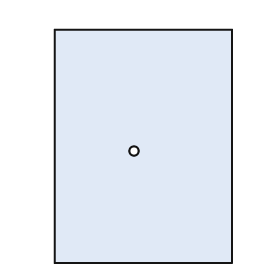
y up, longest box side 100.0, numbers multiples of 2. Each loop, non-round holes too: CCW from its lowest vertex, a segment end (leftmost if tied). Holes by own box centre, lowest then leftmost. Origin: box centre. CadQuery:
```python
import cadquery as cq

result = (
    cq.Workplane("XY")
    .moveTo(-38.0, -50.0)
    .lineTo(38.0, -50.0)
    .lineTo(38.0, 50.0)
    .lineTo(-38.0, 50.0)
    .close()
    .moveTo(-4.0, -2.0)
    .circle(2.0)
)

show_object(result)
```